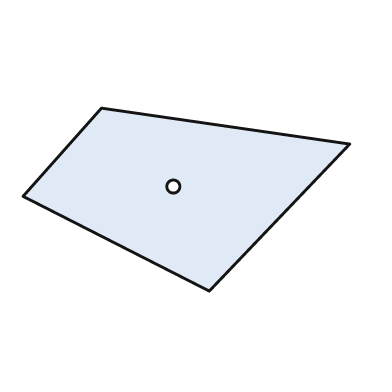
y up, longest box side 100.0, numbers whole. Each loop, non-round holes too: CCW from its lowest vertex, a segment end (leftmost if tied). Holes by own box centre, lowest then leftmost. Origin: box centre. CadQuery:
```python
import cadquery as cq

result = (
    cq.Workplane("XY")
    .moveTo(7.0, -28.0)
    .lineTo(50.0, 17.0)
    .lineTo(-26.0, 28.0)
    .lineTo(-50.0, 1.0)
    .close()
    .moveTo(-4.0, 4.0)
    .circle(2.0)
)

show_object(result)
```